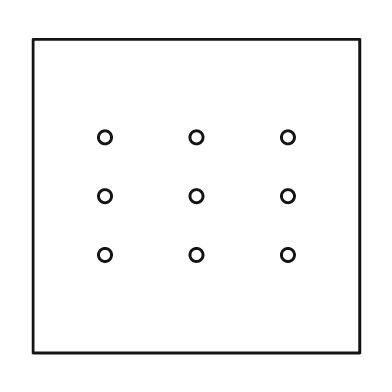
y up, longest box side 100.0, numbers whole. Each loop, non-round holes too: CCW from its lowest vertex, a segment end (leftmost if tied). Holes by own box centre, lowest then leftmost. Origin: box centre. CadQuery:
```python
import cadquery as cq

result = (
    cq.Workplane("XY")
    .moveTo(-50.0, -48.0)
    .lineTo(50.0, -48.0)
    .lineTo(50.0, 48.0)
    .lineTo(-50.0, 48.0)
    .close()
    .moveTo(-28.0, -18.0)
    .circle(2.0)
    .moveTo(0.0, -18.0)
    .circle(2.0)
    .moveTo(28.0, -18.0)
    .circle(2.0)
    .moveTo(-28.0, 0.0)
    .circle(2.0)
    .moveTo(0.0, 0.0)
    .circle(2.0)
    .moveTo(28.0, 0.0)
    .circle(2.0)
    .moveTo(-28.0, 18.0)
    .circle(2.0)
    .moveTo(0.0, 18.0)
    .circle(2.0)
    .moveTo(28.0, 18.0)
    .circle(2.0)
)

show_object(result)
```